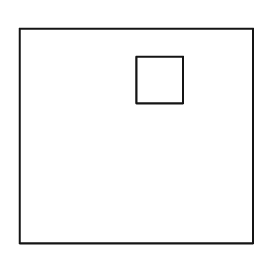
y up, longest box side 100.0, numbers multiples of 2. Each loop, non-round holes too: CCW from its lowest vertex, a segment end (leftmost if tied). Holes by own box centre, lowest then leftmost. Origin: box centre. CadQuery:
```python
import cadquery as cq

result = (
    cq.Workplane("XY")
    .moveTo(-50.0, -46.0)
    .lineTo(50.0, -46.0)
    .lineTo(50.0, 46.0)
    .lineTo(-50.0, 46.0)
    .close()
    .moveTo(0.0, 14.0)
    .lineTo(20.0, 14.0)
    .lineTo(20.0, 34.0)
    .lineTo(0.0, 34.0)
    .close()
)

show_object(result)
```